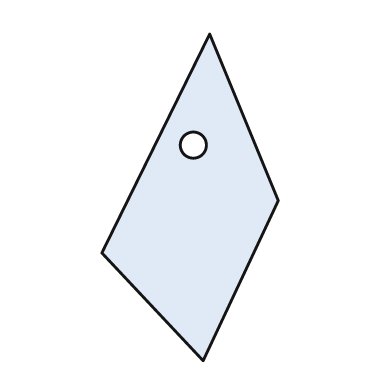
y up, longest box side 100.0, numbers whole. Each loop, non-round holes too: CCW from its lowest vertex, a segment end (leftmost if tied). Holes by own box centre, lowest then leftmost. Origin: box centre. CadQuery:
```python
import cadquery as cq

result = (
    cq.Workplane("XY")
    .moveTo(4.0, -50.0)
    .lineTo(27.0, -1.0)
    .lineTo(6.0, 50.0)
    .lineTo(-27.0, -17.0)
    .close()
    .moveTo(1.0, 16.0)
    .circle(4.0)
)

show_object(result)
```